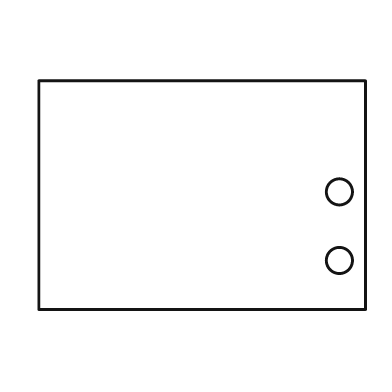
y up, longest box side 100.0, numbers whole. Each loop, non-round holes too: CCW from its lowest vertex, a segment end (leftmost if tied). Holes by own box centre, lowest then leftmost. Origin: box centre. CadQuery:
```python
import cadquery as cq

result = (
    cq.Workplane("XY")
    .moveTo(-50.0, -35.0)
    .lineTo(50.0, -35.0)
    .lineTo(50.0, 35.0)
    .lineTo(-50.0, 35.0)
    .close()
    .moveTo(42.0, -20.0)
    .circle(4.0)
    .moveTo(42.0, 1.0)
    .circle(4.0)
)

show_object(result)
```